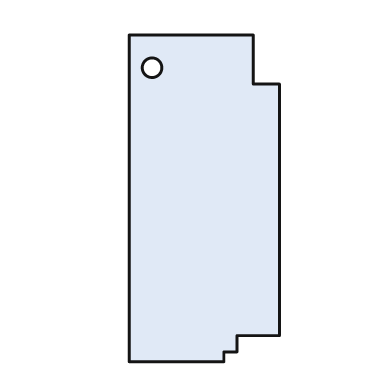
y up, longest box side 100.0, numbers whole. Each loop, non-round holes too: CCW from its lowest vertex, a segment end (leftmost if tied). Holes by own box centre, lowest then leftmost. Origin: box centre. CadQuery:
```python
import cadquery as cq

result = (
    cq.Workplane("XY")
    .moveTo(-23.0, -50.0)
    .lineTo(6.0, -50.0)
    .lineTo(6.0, -47.0)
    .lineTo(10.0, -47.0)
    .lineTo(10.0, -42.0)
    .lineTo(23.0, -42.0)
    .lineTo(23.0, 35.0)
    .lineTo(15.0, 35.0)
    .lineTo(15.0, 50.0)
    .lineTo(-23.0, 50.0)
    .close()
    .moveTo(-16.0, 40.0)
    .circle(3.0)
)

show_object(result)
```